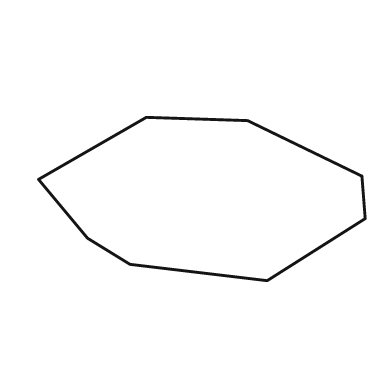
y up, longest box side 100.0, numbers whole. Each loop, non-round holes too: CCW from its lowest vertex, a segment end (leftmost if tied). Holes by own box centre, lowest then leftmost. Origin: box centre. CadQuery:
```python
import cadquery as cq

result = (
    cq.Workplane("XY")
    .moveTo(20.0, -25.0)
    .lineTo(50.0, -6.0)
    .lineTo(49.0, 7.0)
    .lineTo(14.0, 24.0)
    .lineTo(-17.0, 25.0)
    .lineTo(-50.0, 6.0)
    .lineTo(-35.0, -12.0)
    .lineTo(-22.0, -20.0)
    .close()
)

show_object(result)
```